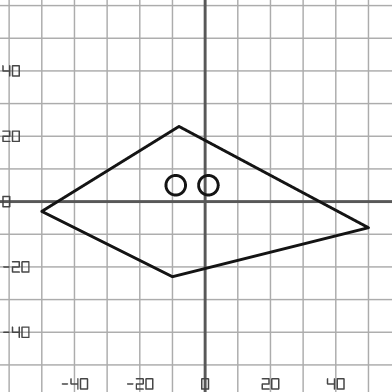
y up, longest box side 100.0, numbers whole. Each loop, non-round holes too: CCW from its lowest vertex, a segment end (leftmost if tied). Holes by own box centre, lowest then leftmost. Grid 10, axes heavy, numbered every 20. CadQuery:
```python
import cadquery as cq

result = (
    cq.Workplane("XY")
    .moveTo(-10.0, -23.0)
    .lineTo(50.0, -8.0)
    .lineTo(-8.0, 23.0)
    .lineTo(-50.0, -3.0)
    .close()
    .moveTo(-9.0, 5.0)
    .circle(3.0)
    .moveTo(1.0, 5.0)
    .circle(3.0)
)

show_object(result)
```